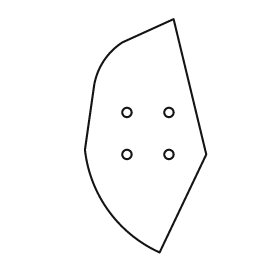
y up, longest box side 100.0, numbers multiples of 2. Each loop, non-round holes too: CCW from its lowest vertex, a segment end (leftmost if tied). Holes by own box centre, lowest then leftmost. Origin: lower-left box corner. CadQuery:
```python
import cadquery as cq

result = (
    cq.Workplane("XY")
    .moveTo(32.0, 0.0)
    .lineTo(52.0, 42.0)
    .lineTo(38.0, 100.0)
    .lineTo(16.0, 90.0)
    .threePointArc((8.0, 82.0), (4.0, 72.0))
    .lineTo(0.0, 44.0)
    .threePointArc((10.0, 18.0), (32.0, 0.0))
    .close()
    .moveTo(18.0, 42.0)
    .circle(2.0)
    .moveTo(36.0, 42.0)
    .circle(2.0)
    .moveTo(18.0, 60.0)
    .circle(2.0)
    .moveTo(36.0, 60.0)
    .circle(2.0)
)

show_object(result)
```